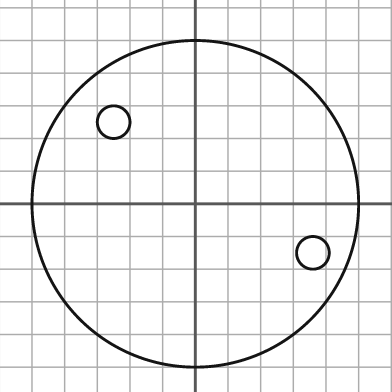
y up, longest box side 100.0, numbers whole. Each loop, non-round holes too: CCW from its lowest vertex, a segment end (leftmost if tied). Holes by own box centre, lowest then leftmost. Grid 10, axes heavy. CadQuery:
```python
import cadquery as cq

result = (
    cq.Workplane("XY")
    .moveTo(0.0, 0.0)
    .circle(50.0)
    .moveTo(36.0, -15.0)
    .circle(5.0)
    .moveTo(-25.0, 25.0)
    .circle(5.0)
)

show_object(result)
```